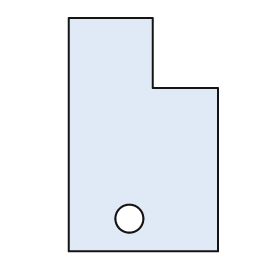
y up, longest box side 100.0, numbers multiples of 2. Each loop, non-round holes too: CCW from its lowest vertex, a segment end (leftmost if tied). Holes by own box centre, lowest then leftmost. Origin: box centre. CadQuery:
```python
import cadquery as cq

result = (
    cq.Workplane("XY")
    .moveTo(-32.0, -50.0)
    .lineTo(32.0, -50.0)
    .lineTo(32.0, 20.0)
    .lineTo(4.0, 20.0)
    .lineTo(4.0, 50.0)
    .lineTo(-32.0, 50.0)
    .close()
    .moveTo(-6.0, -36.0)
    .circle(6.0)
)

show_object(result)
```